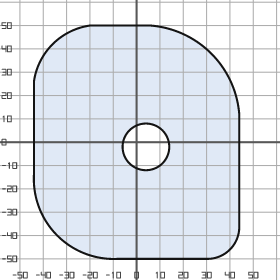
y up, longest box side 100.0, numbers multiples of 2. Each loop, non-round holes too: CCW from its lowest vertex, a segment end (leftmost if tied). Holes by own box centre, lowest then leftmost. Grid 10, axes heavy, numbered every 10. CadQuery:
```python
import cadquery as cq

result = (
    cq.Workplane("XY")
    .moveTo(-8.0, -50.0)
    .lineTo(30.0, -50.0)
    .threePointArc((40.0, -46.0), (44.0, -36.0))
    .lineTo(44.0, 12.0)
    .threePointArc((32.0, 38.0), (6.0, 50.0))
    .lineTo(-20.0, 50.0)
    .threePointArc((-36.0, 42.0), (-44.0, 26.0))
    .lineTo(-44.0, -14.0)
    .threePointArc((-34.0, -40.0), (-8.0, -50.0))
    .close()
    .moveTo(4.0, -2.0)
    .circle(10.0)
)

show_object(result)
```